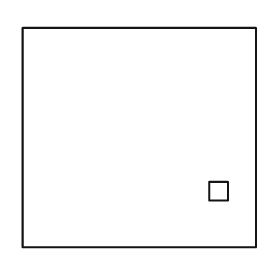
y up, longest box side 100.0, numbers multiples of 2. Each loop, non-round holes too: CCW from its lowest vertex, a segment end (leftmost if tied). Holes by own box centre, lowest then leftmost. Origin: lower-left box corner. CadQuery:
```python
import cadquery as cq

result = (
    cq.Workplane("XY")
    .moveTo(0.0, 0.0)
    .lineTo(100.0, 0.0)
    .lineTo(100.0, 94.0)
    .lineTo(0.0, 94.0)
    .close()
    .moveTo(80.0, 20.0)
    .lineTo(88.0, 20.0)
    .lineTo(88.0, 28.0)
    .lineTo(80.0, 28.0)
    .close()
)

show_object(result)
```